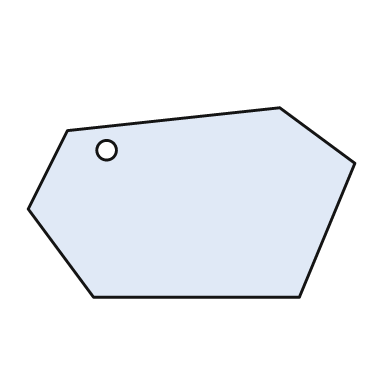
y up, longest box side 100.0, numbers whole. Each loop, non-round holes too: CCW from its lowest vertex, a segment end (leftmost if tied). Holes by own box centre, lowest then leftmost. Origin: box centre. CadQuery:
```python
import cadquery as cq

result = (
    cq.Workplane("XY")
    .moveTo(-30.0, -29.0)
    .lineTo(33.0, -29.0)
    .lineTo(50.0, 12.0)
    .lineTo(27.0, 29.0)
    .lineTo(-38.0, 22.0)
    .lineTo(-50.0, -2.0)
    .close()
    .moveTo(-26.0, 16.0)
    .circle(3.0)
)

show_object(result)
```